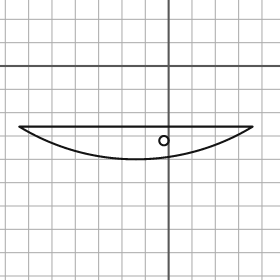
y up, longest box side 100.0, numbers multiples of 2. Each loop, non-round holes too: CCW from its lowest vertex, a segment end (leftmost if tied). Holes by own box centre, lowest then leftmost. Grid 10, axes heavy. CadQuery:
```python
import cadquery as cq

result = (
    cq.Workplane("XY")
    .moveTo(-64.0, -26.0)
    .threePointArc((-14.0, -40.0), (36.0, -26.0))
    .close()
    .moveTo(-2.0, -32.0)
    .circle(2.0)
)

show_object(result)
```